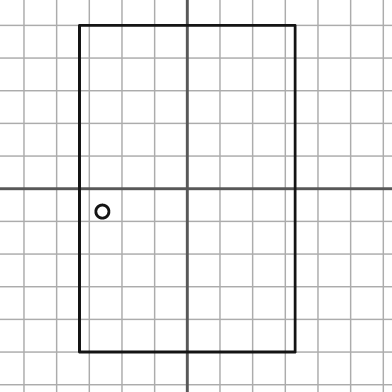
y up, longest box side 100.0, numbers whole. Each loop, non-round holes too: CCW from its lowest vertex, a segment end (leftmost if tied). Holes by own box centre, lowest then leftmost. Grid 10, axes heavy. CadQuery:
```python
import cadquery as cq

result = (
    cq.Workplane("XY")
    .moveTo(-33.0, -50.0)
    .lineTo(33.0, -50.0)
    .lineTo(33.0, 50.0)
    .lineTo(-33.0, 50.0)
    .close()
    .moveTo(-26.0, -7.0)
    .circle(2.0)
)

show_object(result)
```